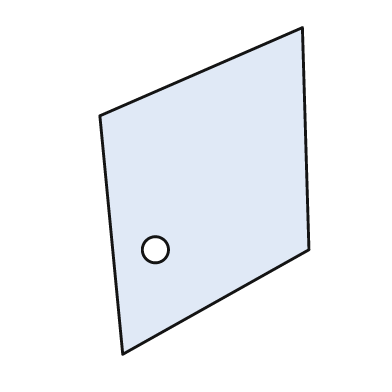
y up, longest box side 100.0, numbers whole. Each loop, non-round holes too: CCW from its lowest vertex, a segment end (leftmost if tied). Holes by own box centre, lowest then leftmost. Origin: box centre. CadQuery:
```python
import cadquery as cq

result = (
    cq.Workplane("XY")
    .moveTo(-25.0, -50.0)
    .lineTo(32.0, -18.0)
    .lineTo(30.0, 50.0)
    .lineTo(-32.0, 23.0)
    .close()
    .moveTo(-15.0, -18.0)
    .circle(4.0)
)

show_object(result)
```